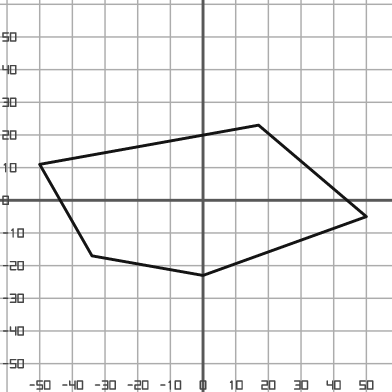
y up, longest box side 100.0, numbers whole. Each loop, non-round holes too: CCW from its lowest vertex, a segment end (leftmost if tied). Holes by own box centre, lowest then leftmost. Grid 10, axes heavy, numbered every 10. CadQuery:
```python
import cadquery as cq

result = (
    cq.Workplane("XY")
    .moveTo(0.0, -23.0)
    .lineTo(50.0, -5.0)
    .lineTo(17.0, 23.0)
    .lineTo(-50.0, 11.0)
    .lineTo(-34.0, -17.0)
    .close()
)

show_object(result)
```